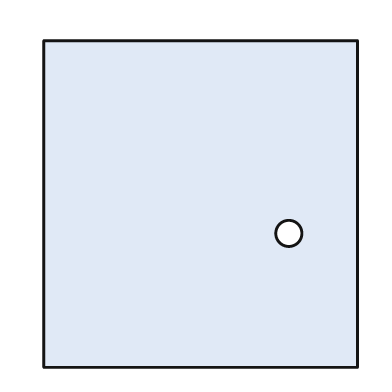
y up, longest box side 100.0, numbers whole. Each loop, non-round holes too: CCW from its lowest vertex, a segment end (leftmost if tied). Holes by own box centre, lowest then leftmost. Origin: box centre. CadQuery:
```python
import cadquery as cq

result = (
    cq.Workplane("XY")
    .moveTo(-48.0, -50.0)
    .lineTo(48.0, -50.0)
    .lineTo(48.0, 50.0)
    .lineTo(-48.0, 50.0)
    .close()
    .moveTo(27.0, -9.0)
    .circle(4.0)
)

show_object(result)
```